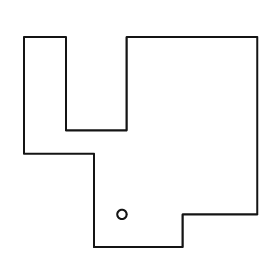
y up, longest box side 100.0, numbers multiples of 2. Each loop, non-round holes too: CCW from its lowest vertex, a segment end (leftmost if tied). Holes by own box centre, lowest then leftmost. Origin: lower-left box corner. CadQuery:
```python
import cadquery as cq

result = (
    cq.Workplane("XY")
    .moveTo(30.0, 0.0)
    .lineTo(68.0, 0.0)
    .lineTo(68.0, 14.0)
    .lineTo(100.0, 14.0)
    .lineTo(100.0, 90.0)
    .lineTo(44.0, 90.0)
    .lineTo(44.0, 50.0)
    .lineTo(18.0, 50.0)
    .lineTo(18.0, 90.0)
    .lineTo(0.0, 90.0)
    .lineTo(0.0, 40.0)
    .lineTo(30.0, 40.0)
    .close()
    .moveTo(42.0, 14.0)
    .circle(2.0)
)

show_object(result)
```